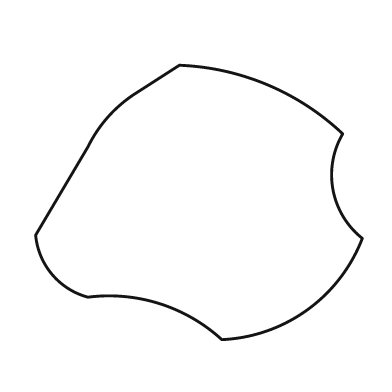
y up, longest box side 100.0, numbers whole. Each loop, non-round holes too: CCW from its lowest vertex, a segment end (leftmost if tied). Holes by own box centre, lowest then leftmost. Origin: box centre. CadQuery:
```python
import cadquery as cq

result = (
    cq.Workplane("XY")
    .moveTo(7.0, -42.0)
    .threePointArc((33.0, -33.0), (50.0, -11.0))
    .threePointArc((41.0, 4.0), (44.0, 21.0))
    .threePointArc((21.0, 36.0), (-6.0, 42.0))
    .lineTo(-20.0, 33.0)
    .threePointArc((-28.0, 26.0), (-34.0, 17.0))
    .lineTo(-50.0, -10.0)
    .threePointArc((-45.0, -22.0), (-34.0, -29.0))
    .threePointArc((-12.0, -31.0), (7.0, -42.0))
    .close()
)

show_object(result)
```